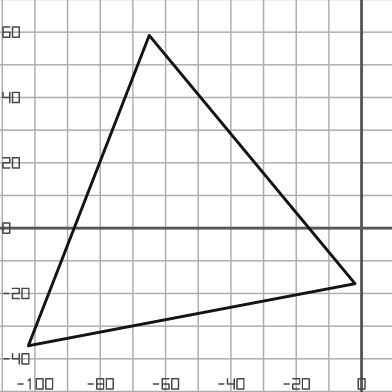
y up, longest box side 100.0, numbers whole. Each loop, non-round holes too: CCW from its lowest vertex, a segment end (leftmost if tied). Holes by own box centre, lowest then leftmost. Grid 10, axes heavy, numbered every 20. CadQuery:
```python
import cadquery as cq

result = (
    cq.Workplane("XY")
    .moveTo(-102.0, -36.0)
    .lineTo(-2.0, -17.0)
    .lineTo(-65.0, 59.0)
    .close()
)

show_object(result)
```